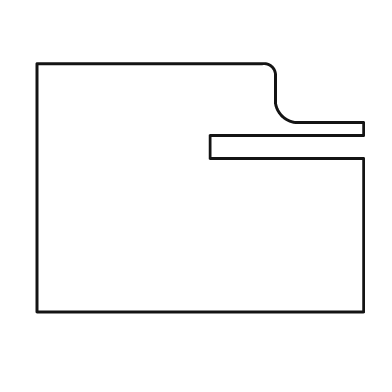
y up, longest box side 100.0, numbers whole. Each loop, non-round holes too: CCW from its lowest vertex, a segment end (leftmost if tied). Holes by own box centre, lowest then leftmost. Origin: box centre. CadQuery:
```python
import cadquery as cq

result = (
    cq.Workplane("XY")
    .moveTo(-50.0, -38.0)
    .lineTo(50.0, -38.0)
    .lineTo(50.0, 9.0)
    .lineTo(3.0, 9.0)
    .lineTo(3.0, 16.0)
    .lineTo(50.0, 16.0)
    .lineTo(50.0, 20.0)
    .lineTo(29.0, 20.0)
    .threePointArc((25.0, 22.0), (23.0, 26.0))
    .lineTo(23.0, 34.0)
    .threePointArc((22.0, 37.0), (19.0, 38.0))
    .lineTo(-50.0, 38.0)
    .close()
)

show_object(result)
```